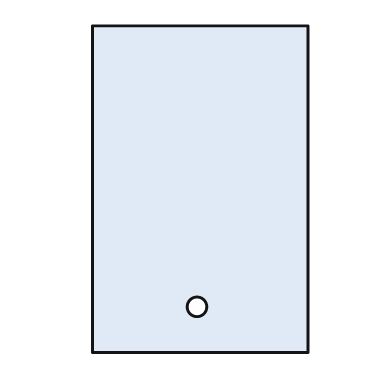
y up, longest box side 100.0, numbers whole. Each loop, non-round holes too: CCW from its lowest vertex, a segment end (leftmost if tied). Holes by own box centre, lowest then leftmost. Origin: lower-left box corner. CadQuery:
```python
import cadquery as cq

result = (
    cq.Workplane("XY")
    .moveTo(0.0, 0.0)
    .lineTo(66.0, 0.0)
    .lineTo(66.0, 100.0)
    .lineTo(0.0, 100.0)
    .close()
    .moveTo(32.0, 14.0)
    .circle(3.0)
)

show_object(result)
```